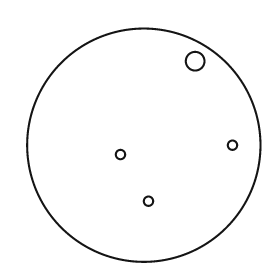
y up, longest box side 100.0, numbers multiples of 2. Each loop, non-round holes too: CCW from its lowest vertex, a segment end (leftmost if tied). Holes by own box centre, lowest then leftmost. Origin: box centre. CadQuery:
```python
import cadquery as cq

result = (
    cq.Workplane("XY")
    .moveTo(0.0, 0.0)
    .circle(50.0)
    .moveTo(2.0, -24.0)
    .circle(2.0)
    .moveTo(-10.0, -4.0)
    .circle(2.0)
    .moveTo(38.0, 0.0)
    .circle(2.0)
    .moveTo(22.0, 36.0)
    .circle(4.0)
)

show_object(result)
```